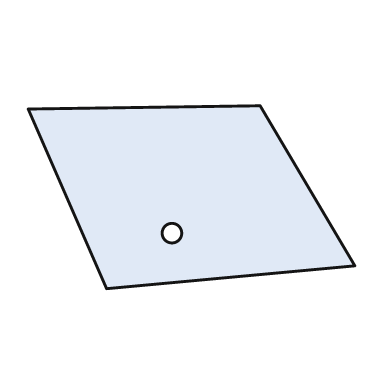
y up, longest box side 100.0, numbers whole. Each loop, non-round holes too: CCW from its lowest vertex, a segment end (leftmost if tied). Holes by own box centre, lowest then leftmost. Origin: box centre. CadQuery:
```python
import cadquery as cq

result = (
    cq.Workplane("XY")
    .moveTo(-26.0, -28.0)
    .lineTo(50.0, -21.0)
    .lineTo(21.0, 28.0)
    .lineTo(-50.0, 27.0)
    .close()
    .moveTo(-6.0, -11.0)
    .circle(3.0)
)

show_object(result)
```